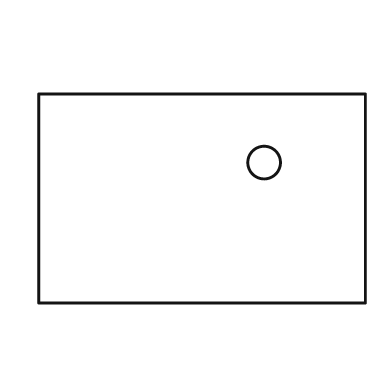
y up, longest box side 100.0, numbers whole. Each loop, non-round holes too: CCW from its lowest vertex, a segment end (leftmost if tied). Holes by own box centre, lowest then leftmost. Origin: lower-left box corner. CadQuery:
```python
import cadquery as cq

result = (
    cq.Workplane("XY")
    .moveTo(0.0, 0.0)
    .lineTo(100.0, 0.0)
    .lineTo(100.0, 64.0)
    .lineTo(0.0, 64.0)
    .close()
    .moveTo(69.0, 43.0)
    .circle(5.0)
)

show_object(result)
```